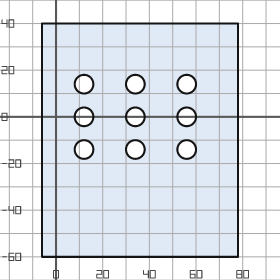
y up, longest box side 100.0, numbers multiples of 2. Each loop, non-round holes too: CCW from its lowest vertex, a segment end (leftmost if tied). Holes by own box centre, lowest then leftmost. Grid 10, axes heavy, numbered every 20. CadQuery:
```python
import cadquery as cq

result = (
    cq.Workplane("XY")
    .moveTo(-6.0, -60.0)
    .lineTo(78.0, -60.0)
    .lineTo(78.0, 40.0)
    .lineTo(-6.0, 40.0)
    .close()
    .moveTo(12.0, -14.0)
    .circle(4.0)
    .moveTo(34.0, -14.0)
    .circle(4.0)
    .moveTo(56.0, -14.0)
    .circle(4.0)
    .moveTo(12.0, 0.0)
    .circle(4.0)
    .moveTo(34.0, 0.0)
    .circle(4.0)
    .moveTo(56.0, 0.0)
    .circle(4.0)
    .moveTo(12.0, 14.0)
    .circle(4.0)
    .moveTo(34.0, 14.0)
    .circle(4.0)
    .moveTo(56.0, 14.0)
    .circle(4.0)
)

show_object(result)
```